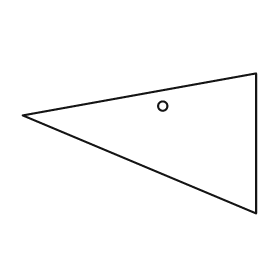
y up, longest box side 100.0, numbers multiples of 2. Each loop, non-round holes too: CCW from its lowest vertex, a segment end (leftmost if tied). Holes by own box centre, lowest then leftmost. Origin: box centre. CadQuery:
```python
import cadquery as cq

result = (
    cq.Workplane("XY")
    .moveTo(50.0, -30.0)
    .lineTo(50.0, 30.0)
    .lineTo(-50.0, 12.0)
    .close()
    .moveTo(10.0, 16.0)
    .circle(2.0)
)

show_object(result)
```